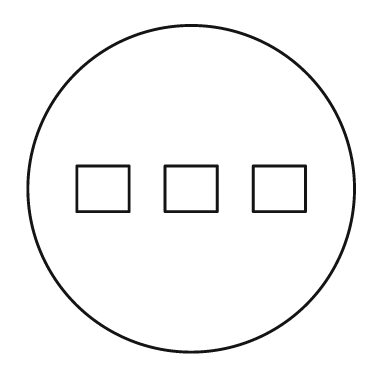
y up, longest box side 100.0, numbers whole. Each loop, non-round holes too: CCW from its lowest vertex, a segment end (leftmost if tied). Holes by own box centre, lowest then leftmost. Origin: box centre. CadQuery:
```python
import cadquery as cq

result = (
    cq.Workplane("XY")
    .moveTo(0.0, 0.0)
    .circle(50.0)
    .moveTo(-35.0, -7.0)
    .lineTo(-19.0, -7.0)
    .lineTo(-19.0, 7.0)
    .lineTo(-35.0, 7.0)
    .close()
    .moveTo(-8.0, -7.0)
    .lineTo(8.0, -7.0)
    .lineTo(8.0, 7.0)
    .lineTo(-8.0, 7.0)
    .close()
    .moveTo(19.0, -7.0)
    .lineTo(35.0, -7.0)
    .lineTo(35.0, 7.0)
    .lineTo(19.0, 7.0)
    .close()
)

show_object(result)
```